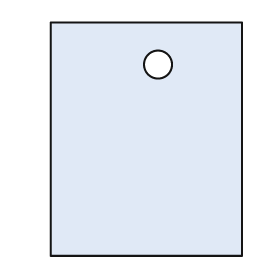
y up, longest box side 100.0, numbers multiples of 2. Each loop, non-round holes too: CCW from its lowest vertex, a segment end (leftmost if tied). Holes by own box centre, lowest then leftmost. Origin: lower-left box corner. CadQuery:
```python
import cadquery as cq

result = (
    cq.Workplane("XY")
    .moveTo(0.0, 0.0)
    .lineTo(82.0, 0.0)
    .lineTo(82.0, 100.0)
    .lineTo(0.0, 100.0)
    .close()
    .moveTo(46.0, 82.0)
    .circle(6.0)
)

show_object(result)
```